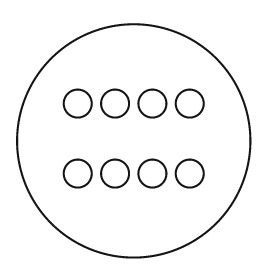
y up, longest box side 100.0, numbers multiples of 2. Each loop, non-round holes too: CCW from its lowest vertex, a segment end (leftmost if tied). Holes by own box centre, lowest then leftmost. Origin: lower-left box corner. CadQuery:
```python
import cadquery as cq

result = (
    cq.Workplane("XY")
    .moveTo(50.0, 50.0)
    .circle(50.0)
    .moveTo(26.0, 36.0)
    .circle(6.0)
    .moveTo(42.0, 36.0)
    .circle(6.0)
    .moveTo(58.0, 36.0)
    .circle(6.0)
    .moveTo(74.0, 36.0)
    .circle(6.0)
    .moveTo(26.0, 66.0)
    .circle(6.0)
    .moveTo(42.0, 66.0)
    .circle(6.0)
    .moveTo(58.0, 66.0)
    .circle(6.0)
    .moveTo(74.0, 66.0)
    .circle(6.0)
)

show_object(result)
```